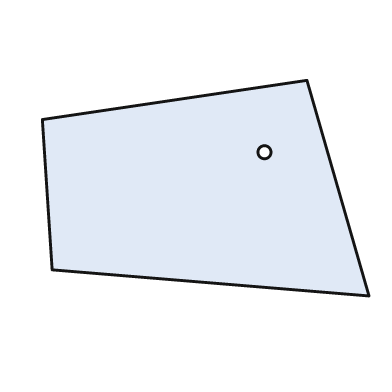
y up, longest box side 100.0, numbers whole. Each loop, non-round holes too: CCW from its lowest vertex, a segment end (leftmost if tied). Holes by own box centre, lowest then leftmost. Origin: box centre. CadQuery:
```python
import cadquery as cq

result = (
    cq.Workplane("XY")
    .moveTo(50.0, -33.0)
    .lineTo(31.0, 33.0)
    .lineTo(-50.0, 21.0)
    .lineTo(-47.0, -25.0)
    .close()
    .moveTo(18.0, 11.0)
    .circle(2.0)
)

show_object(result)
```